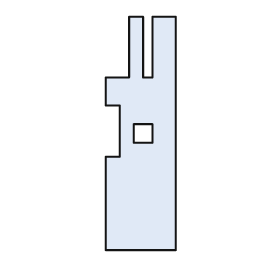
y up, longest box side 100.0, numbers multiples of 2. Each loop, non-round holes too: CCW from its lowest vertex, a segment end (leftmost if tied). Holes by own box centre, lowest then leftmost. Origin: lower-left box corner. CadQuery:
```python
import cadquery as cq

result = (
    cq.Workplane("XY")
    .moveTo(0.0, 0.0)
    .lineTo(30.0, 0.0)
    .lineTo(30.0, 100.0)
    .lineTo(20.0, 100.0)
    .lineTo(20.0, 74.0)
    .lineTo(16.0, 74.0)
    .lineTo(16.0, 100.0)
    .lineTo(10.0, 100.0)
    .lineTo(10.0, 74.0)
    .lineTo(0.0, 74.0)
    .lineTo(0.0, 62.0)
    .lineTo(6.0, 62.0)
    .lineTo(6.0, 40.0)
    .lineTo(0.0, 40.0)
    .close()
    .moveTo(12.0, 46.0)
    .lineTo(20.0, 46.0)
    .lineTo(20.0, 54.0)
    .lineTo(12.0, 54.0)
    .close()
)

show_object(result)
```